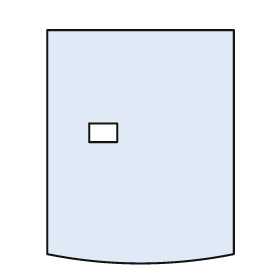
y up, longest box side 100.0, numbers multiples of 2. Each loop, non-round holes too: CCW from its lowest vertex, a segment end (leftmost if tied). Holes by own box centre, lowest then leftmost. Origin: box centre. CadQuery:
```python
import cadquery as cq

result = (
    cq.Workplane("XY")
    .moveTo(-40.0, -46.0)
    .threePointArc((0.0, -50.0), (40.0, -46.0))
    .lineTo(40.0, 50.0)
    .lineTo(-40.0, 50.0)
    .close()
    .moveTo(-22.0, 2.0)
    .lineTo(-10.0, 2.0)
    .lineTo(-10.0, 10.0)
    .lineTo(-22.0, 10.0)
    .close()
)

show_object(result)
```